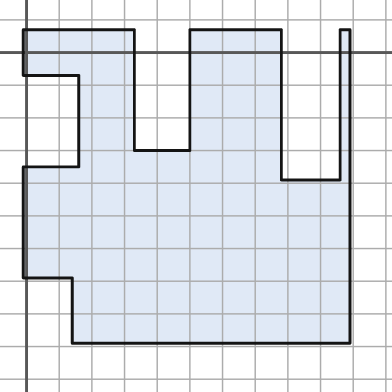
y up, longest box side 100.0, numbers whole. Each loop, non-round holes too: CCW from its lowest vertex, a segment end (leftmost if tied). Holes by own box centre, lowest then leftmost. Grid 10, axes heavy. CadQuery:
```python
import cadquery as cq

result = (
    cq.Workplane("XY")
    .moveTo(14.0, -89.0)
    .lineTo(99.0, -89.0)
    .lineTo(99.0, 7.0)
    .lineTo(96.0, 7.0)
    .lineTo(96.0, -39.0)
    .lineTo(78.0, -39.0)
    .lineTo(78.0, 7.0)
    .lineTo(50.0, 7.0)
    .lineTo(50.0, -30.0)
    .lineTo(33.0, -30.0)
    .lineTo(33.0, 7.0)
    .lineTo(-1.0, 7.0)
    .lineTo(-1.0, -7.0)
    .lineTo(16.0, -7.0)
    .lineTo(16.0, -35.0)
    .lineTo(-1.0, -35.0)
    .lineTo(-1.0, -69.0)
    .lineTo(14.0, -69.0)
    .close()
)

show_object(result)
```